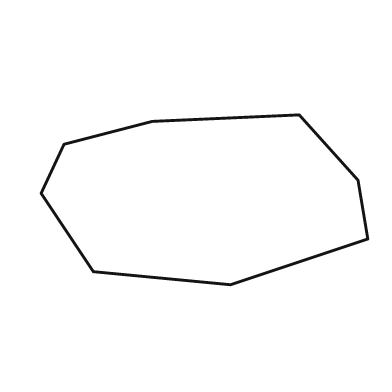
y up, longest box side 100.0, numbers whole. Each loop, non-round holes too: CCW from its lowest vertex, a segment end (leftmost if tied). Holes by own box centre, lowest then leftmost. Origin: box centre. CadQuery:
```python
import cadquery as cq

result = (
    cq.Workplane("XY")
    .moveTo(8.0, -26.0)
    .lineTo(50.0, -12.0)
    .lineTo(47.0, 6.0)
    .lineTo(29.0, 26.0)
    .lineTo(-16.0, 24.0)
    .lineTo(-43.0, 17.0)
    .lineTo(-50.0, 2.0)
    .lineTo(-34.0, -22.0)
    .close()
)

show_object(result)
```